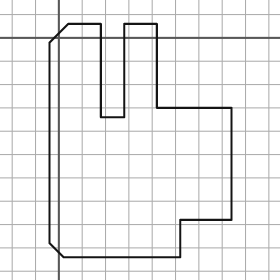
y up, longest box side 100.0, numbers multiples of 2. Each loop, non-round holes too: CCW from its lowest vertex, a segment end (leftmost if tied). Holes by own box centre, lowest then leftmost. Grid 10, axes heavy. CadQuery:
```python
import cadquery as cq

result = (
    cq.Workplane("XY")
    .moveTo(2.0, -94.0)
    .lineTo(52.0, -94.0)
    .lineTo(52.0, -78.0)
    .lineTo(74.0, -78.0)
    .lineTo(74.0, -30.0)
    .lineTo(42.0, -30.0)
    .lineTo(42.0, 6.0)
    .lineTo(28.0, 6.0)
    .lineTo(28.0, -34.0)
    .lineTo(18.0, -34.0)
    .lineTo(18.0, 6.0)
    .lineTo(4.0, 6.0)
    .lineTo(-4.0, -2.0)
    .lineTo(-4.0, -88.0)
    .close()
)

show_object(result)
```